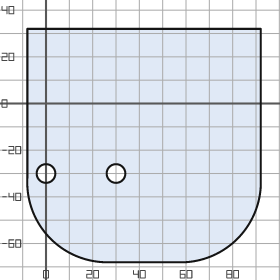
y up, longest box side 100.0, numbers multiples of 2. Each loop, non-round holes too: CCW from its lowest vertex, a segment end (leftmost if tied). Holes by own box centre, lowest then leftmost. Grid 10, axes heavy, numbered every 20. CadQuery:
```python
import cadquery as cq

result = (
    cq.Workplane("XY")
    .moveTo(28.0, -68.0)
    .lineTo(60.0, -68.0)
    .threePointArc((82.0, -58.0), (92.0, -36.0))
    .lineTo(92.0, 32.0)
    .lineTo(-8.0, 32.0)
    .lineTo(-8.0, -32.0)
    .threePointArc((2.0, -58.0), (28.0, -68.0))
    .close()
    .moveTo(0.0, -30.0)
    .circle(4.0)
    .moveTo(30.0, -30.0)
    .circle(4.0)
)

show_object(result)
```